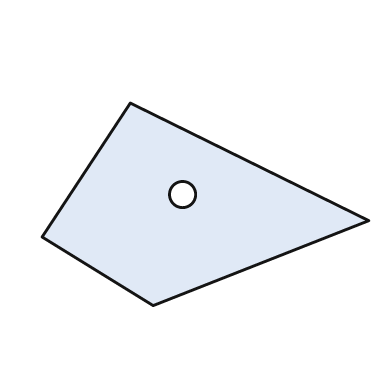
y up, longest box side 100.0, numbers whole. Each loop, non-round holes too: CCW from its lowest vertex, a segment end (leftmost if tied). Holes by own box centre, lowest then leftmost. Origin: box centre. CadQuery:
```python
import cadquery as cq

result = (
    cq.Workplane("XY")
    .moveTo(-16.0, -31.0)
    .lineTo(50.0, -5.0)
    .lineTo(-23.0, 31.0)
    .lineTo(-50.0, -10.0)
    .close()
    .moveTo(-7.0, 3.0)
    .circle(4.0)
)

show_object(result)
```